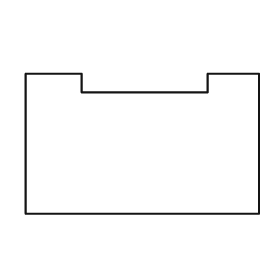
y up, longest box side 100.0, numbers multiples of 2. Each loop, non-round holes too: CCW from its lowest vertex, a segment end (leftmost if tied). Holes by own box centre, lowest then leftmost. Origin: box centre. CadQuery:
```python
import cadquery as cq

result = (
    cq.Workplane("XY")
    .moveTo(-50.0, -30.0)
    .lineTo(50.0, -30.0)
    .lineTo(50.0, 30.0)
    .lineTo(28.0, 30.0)
    .lineTo(28.0, 22.0)
    .lineTo(-26.0, 22.0)
    .lineTo(-26.0, 30.0)
    .lineTo(-50.0, 30.0)
    .close()
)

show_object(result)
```